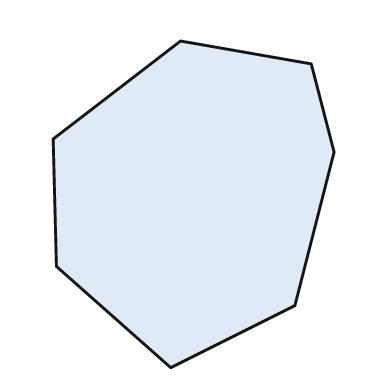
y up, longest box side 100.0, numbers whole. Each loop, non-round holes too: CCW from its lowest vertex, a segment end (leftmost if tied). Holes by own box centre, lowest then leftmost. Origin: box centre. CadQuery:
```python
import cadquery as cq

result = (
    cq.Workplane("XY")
    .moveTo(-7.0, -50.0)
    .lineTo(31.0, -31.0)
    .lineTo(43.0, 16.0)
    .lineTo(36.0, 43.0)
    .lineTo(-4.0, 50.0)
    .lineTo(-43.0, 20.0)
    .lineTo(-42.0, -19.0)
    .close()
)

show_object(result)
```